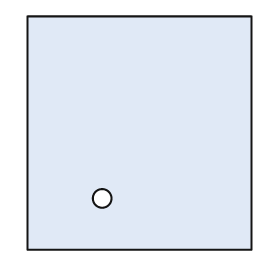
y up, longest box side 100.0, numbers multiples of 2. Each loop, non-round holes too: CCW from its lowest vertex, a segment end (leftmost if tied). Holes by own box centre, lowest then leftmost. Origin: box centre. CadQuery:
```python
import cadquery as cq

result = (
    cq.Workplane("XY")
    .moveTo(-48.0, -50.0)
    .lineTo(48.0, -50.0)
    .lineTo(48.0, 50.0)
    .lineTo(-48.0, 50.0)
    .close()
    .moveTo(-16.0, -28.0)
    .circle(4.0)
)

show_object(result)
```